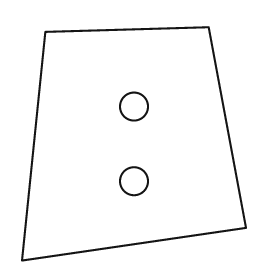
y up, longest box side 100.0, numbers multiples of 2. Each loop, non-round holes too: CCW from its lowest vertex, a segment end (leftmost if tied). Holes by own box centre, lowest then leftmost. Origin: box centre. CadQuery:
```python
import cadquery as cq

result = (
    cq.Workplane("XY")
    .moveTo(-48.0, -50.0)
    .lineTo(48.0, -36.0)
    .lineTo(32.0, 50.0)
    .lineTo(-38.0, 48.0)
    .close()
    .moveTo(0.0, -16.0)
    .circle(6.0)
    .moveTo(0.0, 16.0)
    .circle(6.0)
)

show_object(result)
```